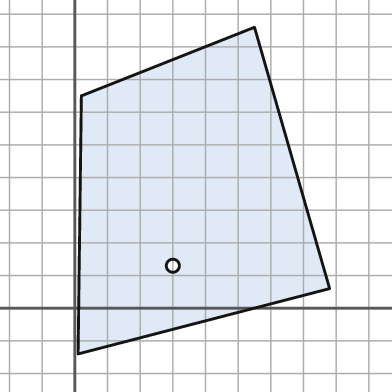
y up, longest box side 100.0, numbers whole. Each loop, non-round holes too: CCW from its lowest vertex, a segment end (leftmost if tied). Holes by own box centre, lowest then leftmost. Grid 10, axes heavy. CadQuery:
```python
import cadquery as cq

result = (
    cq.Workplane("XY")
    .moveTo(1.0, -14.0)
    .lineTo(78.0, 6.0)
    .lineTo(55.0, 86.0)
    .lineTo(2.0, 65.0)
    .close()
    .moveTo(30.0, 13.0)
    .circle(2.0)
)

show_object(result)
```